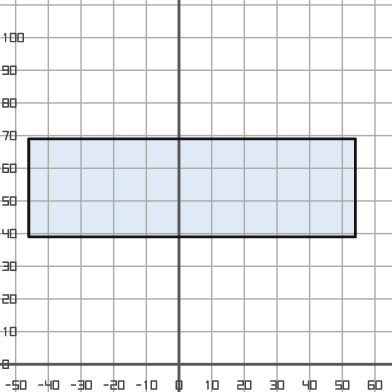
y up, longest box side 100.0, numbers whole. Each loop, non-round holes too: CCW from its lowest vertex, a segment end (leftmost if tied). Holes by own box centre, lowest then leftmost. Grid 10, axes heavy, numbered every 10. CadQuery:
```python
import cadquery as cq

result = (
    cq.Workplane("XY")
    .moveTo(-46.0, 39.0)
    .lineTo(54.0, 39.0)
    .lineTo(54.0, 69.0)
    .lineTo(-46.0, 69.0)
    .close()
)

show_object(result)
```